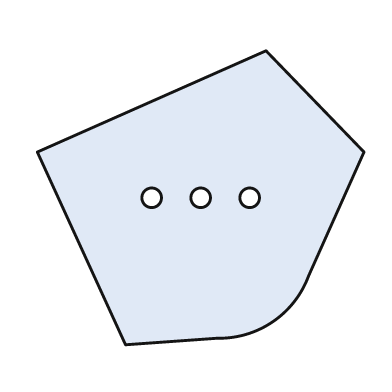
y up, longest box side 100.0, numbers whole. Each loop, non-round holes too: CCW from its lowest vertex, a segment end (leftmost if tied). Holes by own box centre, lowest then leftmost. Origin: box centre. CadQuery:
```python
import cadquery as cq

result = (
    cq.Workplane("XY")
    .moveTo(-23.0, -45.0)
    .lineTo(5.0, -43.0)
    .threePointArc((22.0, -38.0), (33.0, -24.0))
    .lineTo(50.0, 14.0)
    .lineTo(20.0, 45.0)
    .lineTo(-50.0, 14.0)
    .close()
    .moveTo(-15.0, 0.0)
    .circle(3.0)
    .moveTo(0.0, 0.0)
    .circle(3.0)
    .moveTo(15.0, 0.0)
    .circle(3.0)
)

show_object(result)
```